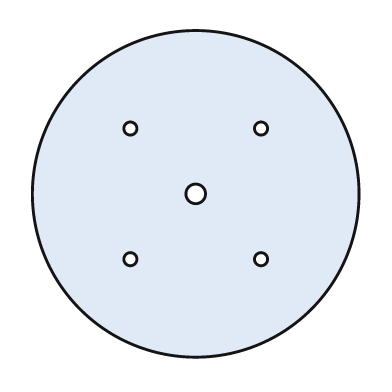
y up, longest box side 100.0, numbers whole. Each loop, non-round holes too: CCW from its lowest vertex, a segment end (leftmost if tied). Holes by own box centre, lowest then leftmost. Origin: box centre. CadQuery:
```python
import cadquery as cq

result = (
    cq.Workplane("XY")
    .moveTo(0.0, 0.0)
    .circle(50.0)
    .moveTo(-20.0, -20.0)
    .circle(2.0)
    .moveTo(20.0, -20.0)
    .circle(2.0)
    .moveTo(0.0, 0.0)
    .circle(3.0)
    .moveTo(-20.0, 20.0)
    .circle(2.0)
    .moveTo(20.0, 20.0)
    .circle(2.0)
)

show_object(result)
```